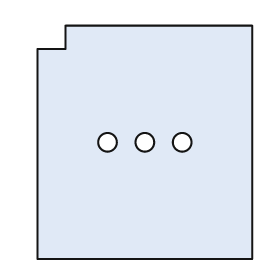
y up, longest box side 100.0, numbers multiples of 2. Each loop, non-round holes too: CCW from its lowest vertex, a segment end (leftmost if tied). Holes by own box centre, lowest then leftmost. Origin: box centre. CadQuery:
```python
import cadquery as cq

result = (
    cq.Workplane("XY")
    .moveTo(-46.0, -50.0)
    .lineTo(46.0, -50.0)
    .lineTo(46.0, 50.0)
    .lineTo(-34.0, 50.0)
    .lineTo(-34.0, 40.0)
    .lineTo(-46.0, 40.0)
    .close()
    .moveTo(-16.0, 0.0)
    .circle(4.0)
    .moveTo(0.0, 0.0)
    .circle(4.0)
    .moveTo(16.0, 0.0)
    .circle(4.0)
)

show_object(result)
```